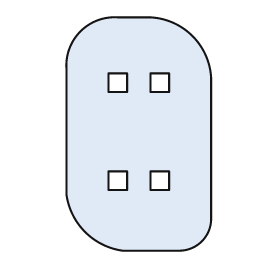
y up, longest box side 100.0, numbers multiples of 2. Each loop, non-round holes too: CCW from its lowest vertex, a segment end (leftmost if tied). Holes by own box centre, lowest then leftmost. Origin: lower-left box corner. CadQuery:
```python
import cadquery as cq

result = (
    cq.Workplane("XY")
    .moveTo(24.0, 0.0)
    .lineTo(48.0, 0.0)
    .threePointArc((58.0, 4.0), (62.0, 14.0))
    .lineTo(62.0, 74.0)
    .threePointArc((54.0, 92.0), (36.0, 100.0))
    .lineTo(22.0, 100.0)
    .threePointArc((6.0, 94.0), (0.0, 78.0))
    .lineTo(0.0, 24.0)
    .threePointArc((8.0, 8.0), (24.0, 0.0))
    .close()
    .moveTo(18.0, 26.0)
    .lineTo(26.0, 26.0)
    .lineTo(26.0, 34.0)
    .lineTo(18.0, 34.0)
    .close()
    .moveTo(36.0, 26.0)
    .lineTo(44.0, 26.0)
    .lineTo(44.0, 34.0)
    .lineTo(36.0, 34.0)
    .close()
    .moveTo(18.0, 68.0)
    .lineTo(26.0, 68.0)
    .lineTo(26.0, 76.0)
    .lineTo(18.0, 76.0)
    .close()
    .moveTo(36.0, 68.0)
    .lineTo(44.0, 68.0)
    .lineTo(44.0, 76.0)
    .lineTo(36.0, 76.0)
    .close()
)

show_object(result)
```